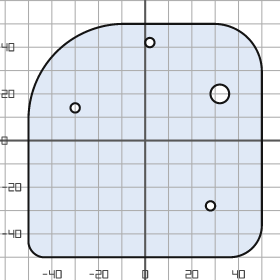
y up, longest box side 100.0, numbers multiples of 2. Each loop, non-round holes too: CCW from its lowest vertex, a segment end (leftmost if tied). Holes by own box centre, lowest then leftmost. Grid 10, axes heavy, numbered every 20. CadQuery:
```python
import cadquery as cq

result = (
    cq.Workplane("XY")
    .moveTo(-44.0, -50.0)
    .lineTo(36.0, -50.0)
    .threePointArc((46.0, -46.0), (50.0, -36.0))
    .lineTo(50.0, 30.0)
    .threePointArc((44.0, 44.0), (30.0, 50.0))
    .lineTo(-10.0, 50.0)
    .threePointArc((-38.0, 38.0), (-50.0, 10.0))
    .lineTo(-50.0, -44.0)
    .threePointArc((-48.0, -48.0), (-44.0, -50.0))
    .close()
    .moveTo(28.0, -28.0)
    .circle(2.0)
    .moveTo(-30.0, 14.0)
    .circle(2.0)
    .moveTo(32.0, 20.0)
    .circle(4.0)
    .moveTo(2.0, 42.0)
    .circle(2.0)
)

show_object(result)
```